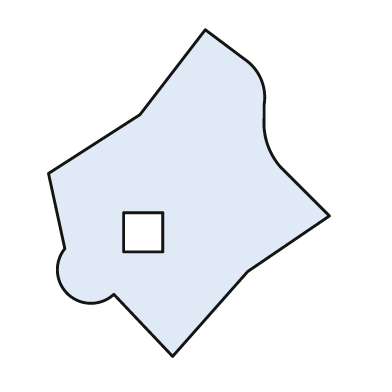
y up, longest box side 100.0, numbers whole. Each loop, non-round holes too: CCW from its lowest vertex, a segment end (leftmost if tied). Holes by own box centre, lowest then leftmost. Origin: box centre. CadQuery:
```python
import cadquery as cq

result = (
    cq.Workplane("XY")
    .moveTo(-5.0, -50.0)
    .lineTo(18.0, -24.0)
    .lineTo(43.0, -7.0)
    .lineTo(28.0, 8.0)
    .threePointArc((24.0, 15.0), (23.0, 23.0))
    .lineTo(23.0, 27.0)
    .threePointArc((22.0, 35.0), (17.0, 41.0))
    .lineTo(5.0, 50.0)
    .lineTo(-15.0, 24.0)
    .lineTo(-43.0, 6.0)
    .lineTo(-38.0, -17.0)
    .threePointArc((-37.0, -31.0), (-23.0, -31.0))
    .close()
    .moveTo(-20.0, -18.0)
    .lineTo(-8.0, -18.0)
    .lineTo(-8.0, -6.0)
    .lineTo(-20.0, -6.0)
    .close()
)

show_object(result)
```